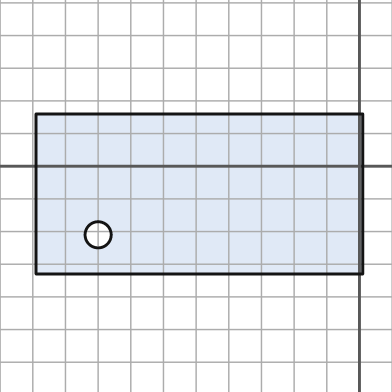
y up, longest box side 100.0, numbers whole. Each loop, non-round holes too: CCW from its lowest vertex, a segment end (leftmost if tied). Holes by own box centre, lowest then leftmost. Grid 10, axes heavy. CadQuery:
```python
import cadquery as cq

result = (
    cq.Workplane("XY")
    .moveTo(-99.0, -33.0)
    .lineTo(1.0, -33.0)
    .lineTo(1.0, 16.0)
    .lineTo(-99.0, 16.0)
    .close()
    .moveTo(-80.0, -21.0)
    .circle(4.0)
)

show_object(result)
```